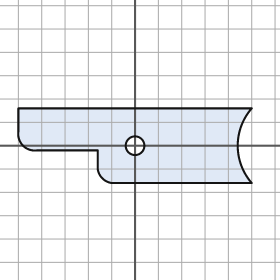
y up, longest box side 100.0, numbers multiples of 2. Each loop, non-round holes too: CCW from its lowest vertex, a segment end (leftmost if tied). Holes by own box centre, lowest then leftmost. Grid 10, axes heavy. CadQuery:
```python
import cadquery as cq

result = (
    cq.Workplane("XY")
    .moveTo(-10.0, -16.0)
    .lineTo(50.0, -16.0)
    .threePointArc((44.0, 0.0), (50.0, 16.0))
    .lineTo(-50.0, 16.0)
    .lineTo(-50.0, 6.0)
    .threePointArc((-48.0, 0.0), (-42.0, -2.0))
    .lineTo(-16.0, -2.0)
    .lineTo(-16.0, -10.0)
    .threePointArc((-14.0, -14.0), (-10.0, -16.0))
    .close()
    .moveTo(0.0, 0.0)
    .circle(4.0)
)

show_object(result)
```